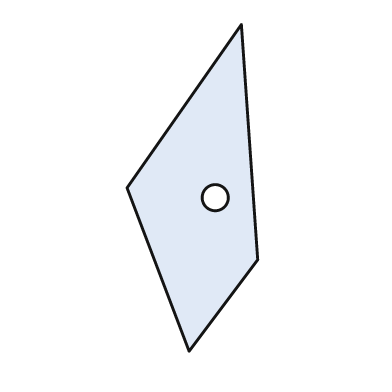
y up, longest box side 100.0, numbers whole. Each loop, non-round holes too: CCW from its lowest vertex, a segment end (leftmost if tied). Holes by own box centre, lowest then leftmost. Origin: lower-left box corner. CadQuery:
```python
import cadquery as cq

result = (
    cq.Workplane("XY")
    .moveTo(19.0, 0.0)
    .lineTo(40.0, 28.0)
    .lineTo(35.0, 100.0)
    .lineTo(0.0, 50.0)
    .close()
    .moveTo(27.0, 47.0)
    .circle(4.0)
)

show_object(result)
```